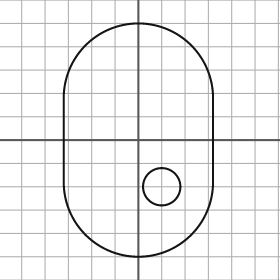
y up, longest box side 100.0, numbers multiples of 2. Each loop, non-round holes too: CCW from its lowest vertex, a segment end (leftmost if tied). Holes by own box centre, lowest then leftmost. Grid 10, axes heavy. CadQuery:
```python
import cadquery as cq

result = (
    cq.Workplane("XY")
    .moveTo(-32.0, -18.0)
    .threePointArc((0.0, -50.0), (32.0, -18.0))
    .lineTo(32.0, 18.0)
    .threePointArc((0.0, 50.0), (-32.0, 18.0))
    .close()
    .moveTo(10.0, -20.0)
    .circle(8.0)
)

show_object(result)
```